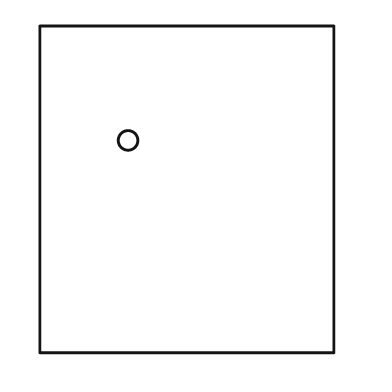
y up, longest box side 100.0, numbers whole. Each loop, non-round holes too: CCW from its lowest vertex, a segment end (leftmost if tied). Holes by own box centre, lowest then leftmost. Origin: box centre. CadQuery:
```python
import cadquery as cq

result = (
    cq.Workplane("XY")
    .moveTo(-45.0, -50.0)
    .lineTo(45.0, -50.0)
    .lineTo(45.0, 50.0)
    .lineTo(-45.0, 50.0)
    .close()
    .moveTo(-18.0, 15.0)
    .circle(3.0)
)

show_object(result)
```